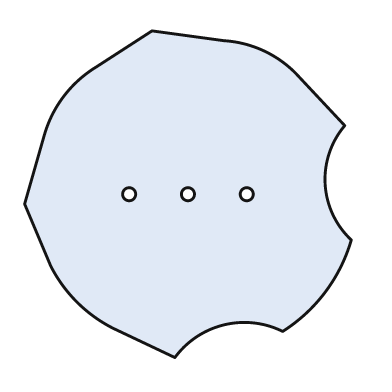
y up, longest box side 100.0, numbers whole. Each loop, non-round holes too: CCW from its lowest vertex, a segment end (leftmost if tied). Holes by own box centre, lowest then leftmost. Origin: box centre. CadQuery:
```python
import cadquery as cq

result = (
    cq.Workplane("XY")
    .moveTo(-4.0, -50.0)
    .threePointArc((11.0, -40.0), (29.0, -42.0))
    .threePointArc((42.0, -30.0), (50.0, -14.0))
    .threePointArc((42.0, 3.0), (48.0, 21.0))
    .lineTo(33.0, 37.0)
    .threePointArc((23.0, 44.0), (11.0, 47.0))
    .lineTo(-11.0, 50.0)
    .lineTo(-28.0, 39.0)
    .threePointArc((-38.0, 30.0), (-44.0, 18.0))
    .lineTo(-50.0, -3.0)
    .lineTo(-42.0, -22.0)
    .threePointArc((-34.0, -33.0), (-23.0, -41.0))
    .close()
    .moveTo(-18.0, 0.0)
    .circle(2.0)
    .moveTo(0.0, 0.0)
    .circle(2.0)
    .moveTo(18.0, 0.0)
    .circle(2.0)
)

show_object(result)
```